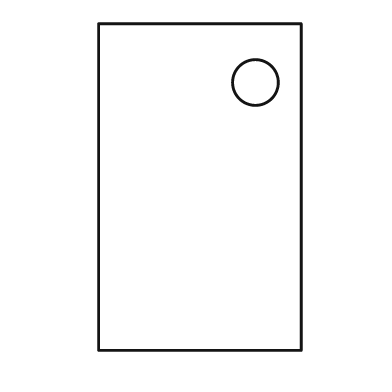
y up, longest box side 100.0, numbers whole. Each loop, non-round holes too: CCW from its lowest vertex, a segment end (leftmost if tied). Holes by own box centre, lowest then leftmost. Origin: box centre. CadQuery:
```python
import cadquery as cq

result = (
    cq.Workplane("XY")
    .moveTo(-31.0, -50.0)
    .lineTo(31.0, -50.0)
    .lineTo(31.0, 50.0)
    .lineTo(-31.0, 50.0)
    .close()
    .moveTo(17.0, 32.0)
    .circle(7.0)
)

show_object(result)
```